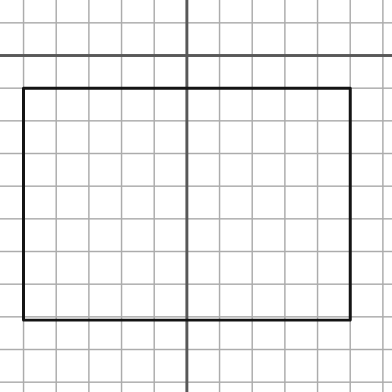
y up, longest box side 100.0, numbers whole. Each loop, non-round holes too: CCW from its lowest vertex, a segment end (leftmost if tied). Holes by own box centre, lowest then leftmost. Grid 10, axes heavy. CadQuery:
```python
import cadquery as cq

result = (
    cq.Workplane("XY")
    .moveTo(-50.0, -81.0)
    .lineTo(50.0, -81.0)
    .lineTo(50.0, -10.0)
    .lineTo(-50.0, -10.0)
    .close()
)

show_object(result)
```